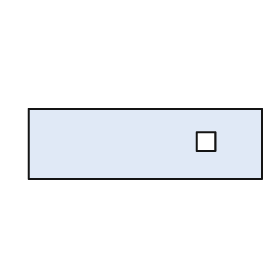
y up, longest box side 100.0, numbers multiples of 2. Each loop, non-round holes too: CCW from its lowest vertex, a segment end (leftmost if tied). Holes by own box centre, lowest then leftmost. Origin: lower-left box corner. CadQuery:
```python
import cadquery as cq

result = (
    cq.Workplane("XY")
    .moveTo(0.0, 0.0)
    .lineTo(100.0, 0.0)
    .lineTo(100.0, 30.0)
    .lineTo(0.0, 30.0)
    .close()
    .moveTo(72.0, 12.0)
    .lineTo(80.0, 12.0)
    .lineTo(80.0, 20.0)
    .lineTo(72.0, 20.0)
    .close()
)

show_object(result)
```